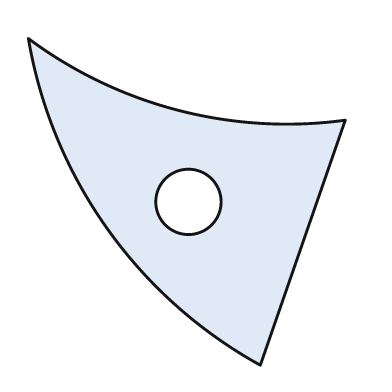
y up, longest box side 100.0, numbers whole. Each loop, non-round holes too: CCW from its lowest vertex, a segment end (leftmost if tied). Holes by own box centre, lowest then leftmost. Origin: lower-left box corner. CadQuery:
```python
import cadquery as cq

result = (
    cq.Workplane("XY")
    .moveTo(71.0, 0.0)
    .lineTo(97.0, 75.0)
    .threePointArc((46.0, 78.0), (0.0, 100.0))
    .threePointArc((24.0, 42.0), (71.0, 0.0))
    .close()
    .moveTo(49.0, 50.0)
    .circle(10.0)
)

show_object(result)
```